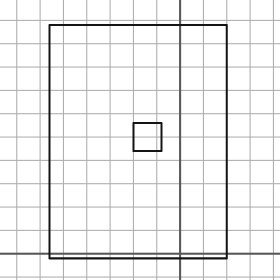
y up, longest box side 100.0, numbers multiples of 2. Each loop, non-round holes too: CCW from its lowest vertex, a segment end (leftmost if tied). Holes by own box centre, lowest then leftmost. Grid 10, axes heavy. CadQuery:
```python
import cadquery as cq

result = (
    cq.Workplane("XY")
    .moveTo(-56.0, -2.0)
    .lineTo(20.0, -2.0)
    .lineTo(20.0, 98.0)
    .lineTo(-56.0, 98.0)
    .close()
    .moveTo(-20.0, 44.0)
    .lineTo(-8.0, 44.0)
    .lineTo(-8.0, 56.0)
    .lineTo(-20.0, 56.0)
    .close()
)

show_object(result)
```